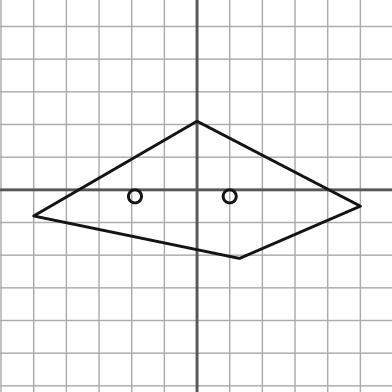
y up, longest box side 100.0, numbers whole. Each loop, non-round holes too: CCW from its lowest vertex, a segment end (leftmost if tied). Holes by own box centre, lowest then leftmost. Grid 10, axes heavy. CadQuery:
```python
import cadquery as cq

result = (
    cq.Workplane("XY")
    .moveTo(13.0, -21.0)
    .lineTo(50.0, -5.0)
    .lineTo(0.0, 21.0)
    .lineTo(-50.0, -8.0)
    .close()
    .moveTo(-19.0, -2.0)
    .circle(2.0)
    .moveTo(10.0, -2.0)
    .circle(2.0)
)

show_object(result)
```